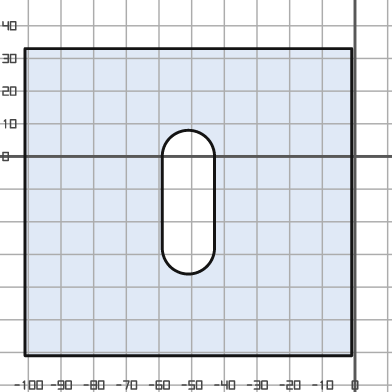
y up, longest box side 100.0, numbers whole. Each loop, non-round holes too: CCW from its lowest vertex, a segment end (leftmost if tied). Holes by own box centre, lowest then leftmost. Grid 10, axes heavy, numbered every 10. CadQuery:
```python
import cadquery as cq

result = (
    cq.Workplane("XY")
    .moveTo(-101.0, -61.0)
    .lineTo(-1.0, -61.0)
    .lineTo(-1.0, 33.0)
    .lineTo(-101.0, 33.0)
    .close()
    .moveTo(-59.0, -28.0)
    .threePointArc((-51.0, -36.0), (-43.0, -28.0))
    .lineTo(-43.0, 0.0)
    .threePointArc((-51.0, 8.0), (-59.0, 0.0))
    .close()
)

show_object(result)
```